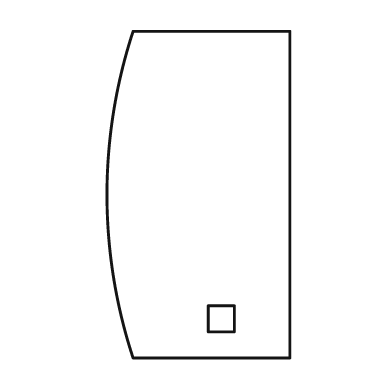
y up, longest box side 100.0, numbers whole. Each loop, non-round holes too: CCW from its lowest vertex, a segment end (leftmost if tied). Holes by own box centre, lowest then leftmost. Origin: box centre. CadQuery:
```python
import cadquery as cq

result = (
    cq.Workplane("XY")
    .moveTo(-20.0, -50.0)
    .lineTo(28.0, -50.0)
    .lineTo(28.0, 50.0)
    .lineTo(-20.0, 50.0)
    .threePointArc((-28.0, 0.0), (-20.0, -50.0))
    .close()
    .moveTo(3.0, -42.0)
    .lineTo(11.0, -42.0)
    .lineTo(11.0, -34.0)
    .lineTo(3.0, -34.0)
    .close()
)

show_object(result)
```